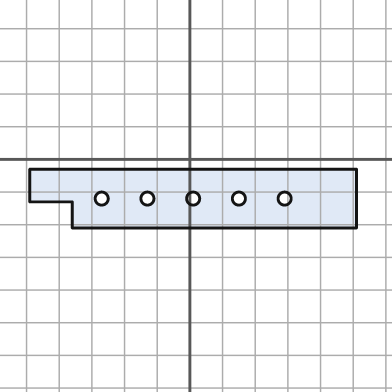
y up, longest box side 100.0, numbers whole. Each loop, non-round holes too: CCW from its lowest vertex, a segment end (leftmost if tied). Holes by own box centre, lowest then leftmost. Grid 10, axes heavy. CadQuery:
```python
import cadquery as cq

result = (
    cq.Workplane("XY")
    .moveTo(-36.0, -21.0)
    .lineTo(51.0, -21.0)
    .lineTo(51.0, -3.0)
    .lineTo(-49.0, -3.0)
    .lineTo(-49.0, -13.0)
    .lineTo(-36.0, -13.0)
    .close()
    .moveTo(-27.0, -12.0)
    .circle(2.0)
    .moveTo(-13.0, -12.0)
    .circle(2.0)
    .moveTo(1.0, -12.0)
    .circle(2.0)
    .moveTo(15.0, -12.0)
    .circle(2.0)
    .moveTo(29.0, -12.0)
    .circle(2.0)
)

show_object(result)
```